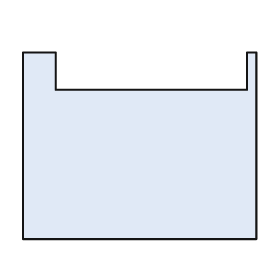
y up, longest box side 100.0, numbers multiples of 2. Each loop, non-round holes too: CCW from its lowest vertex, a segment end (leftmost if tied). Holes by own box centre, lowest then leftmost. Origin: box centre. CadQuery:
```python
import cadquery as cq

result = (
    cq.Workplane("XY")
    .moveTo(-50.0, -40.0)
    .lineTo(50.0, -40.0)
    .lineTo(50.0, 40.0)
    .lineTo(46.0, 40.0)
    .lineTo(46.0, 24.0)
    .lineTo(-36.0, 24.0)
    .lineTo(-36.0, 40.0)
    .lineTo(-50.0, 40.0)
    .close()
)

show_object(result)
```